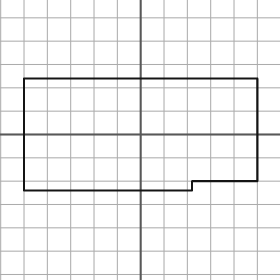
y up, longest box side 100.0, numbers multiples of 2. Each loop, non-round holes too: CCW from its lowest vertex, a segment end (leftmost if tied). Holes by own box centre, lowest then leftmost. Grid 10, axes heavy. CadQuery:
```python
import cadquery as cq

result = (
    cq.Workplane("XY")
    .moveTo(-50.0, -24.0)
    .lineTo(22.0, -24.0)
    .lineTo(22.0, -20.0)
    .lineTo(50.0, -20.0)
    .lineTo(50.0, 24.0)
    .lineTo(-50.0, 24.0)
    .close()
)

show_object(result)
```